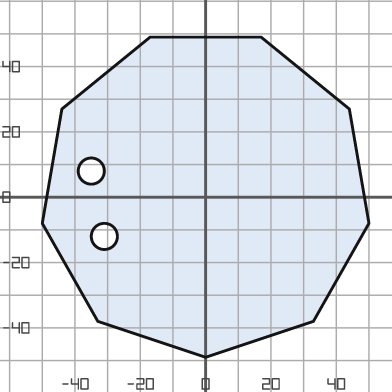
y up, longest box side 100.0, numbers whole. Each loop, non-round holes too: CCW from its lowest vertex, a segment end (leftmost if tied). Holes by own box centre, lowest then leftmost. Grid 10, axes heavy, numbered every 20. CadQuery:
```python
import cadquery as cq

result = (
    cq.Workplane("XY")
    .moveTo(0.0, -49.0)
    .lineTo(33.0, -38.0)
    .lineTo(50.0, -8.0)
    .lineTo(44.0, 27.0)
    .lineTo(17.0, 49.0)
    .lineTo(-17.0, 49.0)
    .lineTo(-44.0, 27.0)
    .lineTo(-50.0, -8.0)
    .lineTo(-33.0, -38.0)
    .close()
    .moveTo(-31.0, -12.0)
    .circle(4.0)
    .moveTo(-35.0, 8.0)
    .circle(4.0)
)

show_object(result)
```